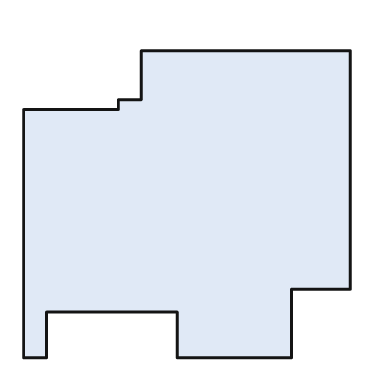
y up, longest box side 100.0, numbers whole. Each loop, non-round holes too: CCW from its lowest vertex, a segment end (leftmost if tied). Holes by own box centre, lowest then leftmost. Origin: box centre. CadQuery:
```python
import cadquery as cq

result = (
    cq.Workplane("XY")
    .moveTo(-50.0, -47.0)
    .lineTo(-43.0, -47.0)
    .lineTo(-43.0, -33.0)
    .lineTo(-3.0, -33.0)
    .lineTo(-3.0, -47.0)
    .lineTo(32.0, -47.0)
    .lineTo(32.0, -26.0)
    .lineTo(50.0, -26.0)
    .lineTo(50.0, 47.0)
    .lineTo(-14.0, 47.0)
    .lineTo(-14.0, 32.0)
    .lineTo(-21.0, 32.0)
    .lineTo(-21.0, 29.0)
    .lineTo(-50.0, 29.0)
    .close()
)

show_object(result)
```